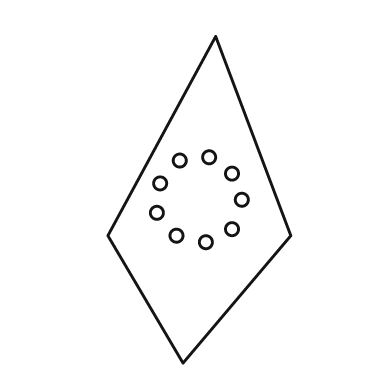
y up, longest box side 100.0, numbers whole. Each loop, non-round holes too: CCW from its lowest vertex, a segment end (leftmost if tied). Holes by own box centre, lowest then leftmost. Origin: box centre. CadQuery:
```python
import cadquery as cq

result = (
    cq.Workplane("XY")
    .moveTo(-5.0, -50.0)
    .lineTo(28.0, -11.0)
    .lineTo(5.0, 50.0)
    .lineTo(-28.0, -11.0)
    .close()
    .moveTo(2.0, -13.0)
    .circle(2.0)
    .moveTo(-7.0, -11.0)
    .circle(2.0)
    .moveTo(10.0, -9.0)
    .circle(2.0)
    .moveTo(-13.0, -4.0)
    .circle(2.0)
    .moveTo(13.0, 0.0)
    .circle(2.0)
    .moveTo(-12.0, 5.0)
    .circle(2.0)
    .moveTo(10.0, 8.0)
    .circle(2.0)
    .moveTo(-6.0, 12.0)
    .circle(2.0)
    .moveTo(3.0, 13.0)
    .circle(2.0)
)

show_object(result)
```